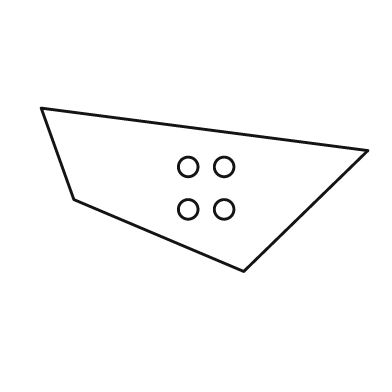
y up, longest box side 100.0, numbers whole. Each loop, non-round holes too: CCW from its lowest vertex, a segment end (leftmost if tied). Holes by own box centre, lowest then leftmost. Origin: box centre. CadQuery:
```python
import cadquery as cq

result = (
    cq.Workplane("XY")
    .moveTo(12.0, -25.0)
    .lineTo(50.0, 12.0)
    .lineTo(-50.0, 25.0)
    .lineTo(-40.0, -3.0)
    .close()
    .moveTo(-5.0, -6.0)
    .circle(3.0)
    .moveTo(6.0, -6.0)
    .circle(3.0)
    .moveTo(-5.0, 7.0)
    .circle(3.0)
    .moveTo(6.0, 7.0)
    .circle(3.0)
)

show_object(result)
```